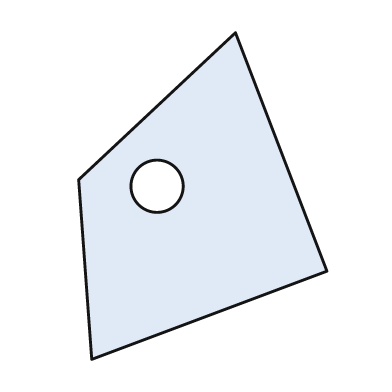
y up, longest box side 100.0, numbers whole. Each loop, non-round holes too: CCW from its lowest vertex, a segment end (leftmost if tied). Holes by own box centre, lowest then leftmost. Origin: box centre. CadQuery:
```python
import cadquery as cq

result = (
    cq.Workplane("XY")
    .moveTo(-34.0, -50.0)
    .lineTo(38.0, -23.0)
    .lineTo(10.0, 50.0)
    .lineTo(-38.0, 5.0)
    .close()
    .moveTo(-14.0, 3.0)
    .circle(8.0)
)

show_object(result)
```